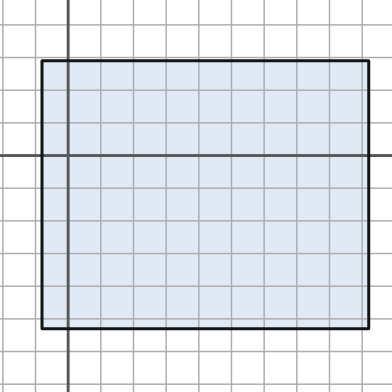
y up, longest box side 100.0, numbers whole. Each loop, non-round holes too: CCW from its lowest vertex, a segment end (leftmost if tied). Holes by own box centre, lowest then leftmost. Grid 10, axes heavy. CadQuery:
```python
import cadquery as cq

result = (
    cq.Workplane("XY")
    .moveTo(-8.0, -53.0)
    .lineTo(92.0, -53.0)
    .lineTo(92.0, 29.0)
    .lineTo(-8.0, 29.0)
    .close()
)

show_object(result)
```